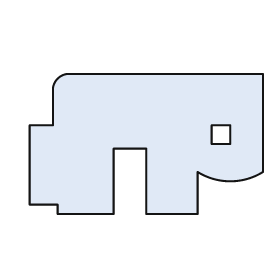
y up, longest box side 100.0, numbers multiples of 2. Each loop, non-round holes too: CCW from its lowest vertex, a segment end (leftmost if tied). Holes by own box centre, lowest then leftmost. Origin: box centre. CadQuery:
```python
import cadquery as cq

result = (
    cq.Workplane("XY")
    .moveTo(-38.0, -30.0)
    .lineTo(-14.0, -30.0)
    .lineTo(-14.0, -2.0)
    .lineTo(0.0, -2.0)
    .lineTo(0.0, -30.0)
    .lineTo(22.0, -30.0)
    .lineTo(22.0, -12.0)
    .threePointArc((36.0, -16.0), (50.0, -12.0))
    .lineTo(50.0, 30.0)
    .lineTo(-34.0, 30.0)
    .threePointArc((-38.0, 28.0), (-40.0, 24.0))
    .lineTo(-40.0, 8.0)
    .lineTo(-50.0, 8.0)
    .lineTo(-50.0, -26.0)
    .lineTo(-38.0, -26.0)
    .close()
    .moveTo(28.0, 0.0)
    .lineTo(36.0, 0.0)
    .lineTo(36.0, 8.0)
    .lineTo(28.0, 8.0)
    .close()
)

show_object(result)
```